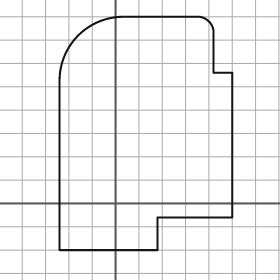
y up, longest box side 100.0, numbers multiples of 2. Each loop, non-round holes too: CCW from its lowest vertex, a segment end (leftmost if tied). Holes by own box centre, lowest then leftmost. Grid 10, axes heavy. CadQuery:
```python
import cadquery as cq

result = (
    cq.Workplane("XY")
    .moveTo(-24.0, -20.0)
    .lineTo(18.0, -20.0)
    .lineTo(18.0, -6.0)
    .lineTo(50.0, -6.0)
    .lineTo(50.0, 56.0)
    .lineTo(42.0, 56.0)
    .lineTo(42.0, 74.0)
    .threePointArc((40.0, 78.0), (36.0, 80.0))
    .lineTo(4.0, 80.0)
    .threePointArc((-16.0, 72.0), (-24.0, 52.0))
    .close()
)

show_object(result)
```